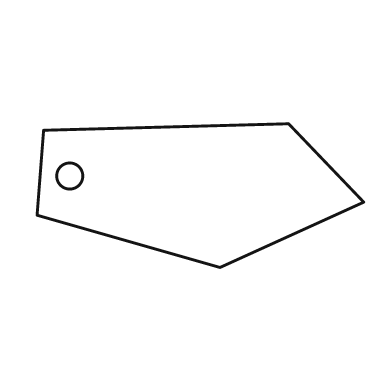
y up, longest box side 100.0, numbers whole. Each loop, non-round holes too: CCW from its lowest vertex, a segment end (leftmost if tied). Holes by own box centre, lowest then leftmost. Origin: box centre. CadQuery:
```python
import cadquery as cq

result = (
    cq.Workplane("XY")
    .moveTo(6.0, -22.0)
    .lineTo(50.0, -2.0)
    .lineTo(27.0, 22.0)
    .lineTo(-48.0, 20.0)
    .lineTo(-50.0, -6.0)
    .close()
    .moveTo(-40.0, 6.0)
    .circle(4.0)
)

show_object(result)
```